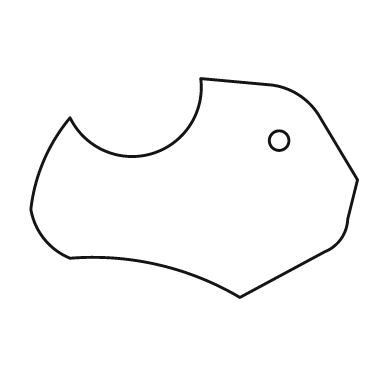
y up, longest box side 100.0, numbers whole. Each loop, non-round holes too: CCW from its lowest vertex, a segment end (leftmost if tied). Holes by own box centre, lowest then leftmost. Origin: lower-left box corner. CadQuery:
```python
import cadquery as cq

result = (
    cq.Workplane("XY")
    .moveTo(64.0, 0.0)
    .lineTo(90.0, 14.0)
    .threePointArc((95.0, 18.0), (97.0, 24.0))
    .lineTo(100.0, 36.0)
    .lineTo(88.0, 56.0)
    .threePointArc((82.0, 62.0), (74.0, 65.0))
    .lineTo(52.0, 67.0)
    .threePointArc((37.0, 44.0), (12.0, 55.0))
    .threePointArc((4.0, 42.0), (0.0, 27.0))
    .threePointArc((4.0, 18.0), (12.0, 12.0))
    .threePointArc((39.0, 10.0), (64.0, 0.0))
    .close()
    .moveTo(76.0, 48.0)
    .circle(3.0)
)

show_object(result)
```